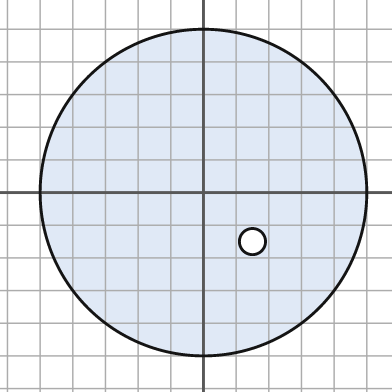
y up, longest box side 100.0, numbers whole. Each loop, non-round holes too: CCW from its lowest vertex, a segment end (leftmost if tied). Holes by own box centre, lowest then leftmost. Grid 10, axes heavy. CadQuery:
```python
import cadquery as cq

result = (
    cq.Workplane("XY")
    .moveTo(0.0, 0.0)
    .circle(50.0)
    .moveTo(15.0, -15.0)
    .circle(4.0)
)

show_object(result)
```